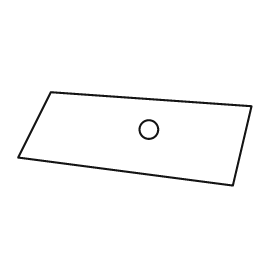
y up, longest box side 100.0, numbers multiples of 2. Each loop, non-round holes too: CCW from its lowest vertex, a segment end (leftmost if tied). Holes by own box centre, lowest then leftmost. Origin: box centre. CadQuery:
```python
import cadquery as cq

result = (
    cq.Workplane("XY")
    .moveTo(42.0, -20.0)
    .lineTo(50.0, 14.0)
    .lineTo(-36.0, 20.0)
    .lineTo(-50.0, -8.0)
    .close()
    .moveTo(6.0, 4.0)
    .circle(4.0)
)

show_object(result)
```